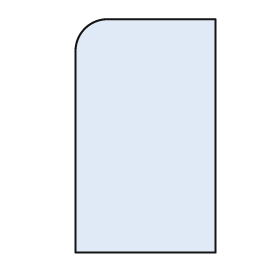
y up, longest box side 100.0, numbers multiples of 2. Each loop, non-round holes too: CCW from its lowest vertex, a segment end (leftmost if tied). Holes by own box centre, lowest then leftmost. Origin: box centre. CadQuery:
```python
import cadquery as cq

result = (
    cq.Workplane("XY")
    .moveTo(-30.0, -50.0)
    .lineTo(30.0, -50.0)
    .lineTo(30.0, 50.0)
    .lineTo(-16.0, 50.0)
    .threePointArc((-26.0, 46.0), (-30.0, 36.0))
    .close()
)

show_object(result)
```